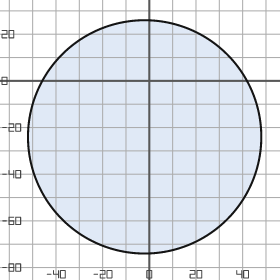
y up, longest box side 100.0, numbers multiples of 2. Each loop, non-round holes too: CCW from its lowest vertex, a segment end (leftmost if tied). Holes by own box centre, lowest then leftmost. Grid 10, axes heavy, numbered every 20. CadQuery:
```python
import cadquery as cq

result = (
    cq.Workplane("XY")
    .moveTo(-2.0, -24.0)
    .circle(50.0)
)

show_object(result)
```